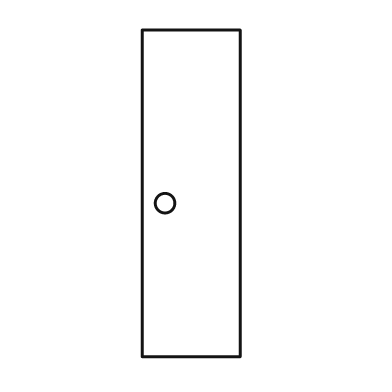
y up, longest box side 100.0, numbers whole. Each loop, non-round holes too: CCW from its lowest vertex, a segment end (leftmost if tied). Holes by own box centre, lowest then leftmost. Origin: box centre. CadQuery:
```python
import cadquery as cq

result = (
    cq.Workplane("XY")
    .moveTo(-15.0, -50.0)
    .lineTo(15.0, -50.0)
    .lineTo(15.0, 50.0)
    .lineTo(-15.0, 50.0)
    .close()
    .moveTo(-8.0, -3.0)
    .circle(3.0)
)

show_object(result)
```